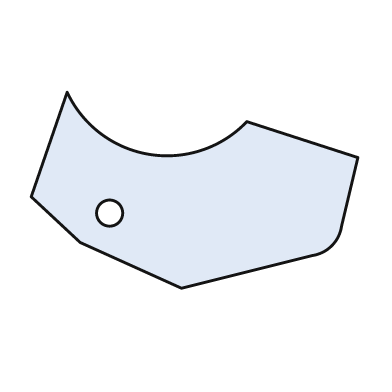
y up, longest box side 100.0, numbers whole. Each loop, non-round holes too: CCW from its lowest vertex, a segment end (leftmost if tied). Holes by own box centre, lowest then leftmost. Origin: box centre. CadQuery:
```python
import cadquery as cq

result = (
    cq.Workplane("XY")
    .moveTo(-4.0, -30.0)
    .lineTo(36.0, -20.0)
    .threePointArc((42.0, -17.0), (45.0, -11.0))
    .lineTo(50.0, 10.0)
    .lineTo(16.0, 21.0)
    .threePointArc((-14.0, 11.0), (-39.0, 30.0))
    .lineTo(-50.0, -2.0)
    .lineTo(-35.0, -16.0)
    .close()
    .moveTo(-26.0, -7.0)
    .circle(4.0)
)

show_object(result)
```